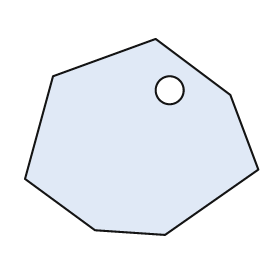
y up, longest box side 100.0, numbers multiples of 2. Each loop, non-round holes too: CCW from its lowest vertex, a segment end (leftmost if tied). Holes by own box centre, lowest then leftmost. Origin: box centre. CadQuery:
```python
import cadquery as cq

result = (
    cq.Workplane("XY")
    .moveTo(10.0, -42.0)
    .lineTo(50.0, -14.0)
    .lineTo(38.0, 18.0)
    .lineTo(6.0, 42.0)
    .lineTo(-38.0, 26.0)
    .lineTo(-50.0, -18.0)
    .lineTo(-20.0, -40.0)
    .close()
    .moveTo(12.0, 20.0)
    .circle(6.0)
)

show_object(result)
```